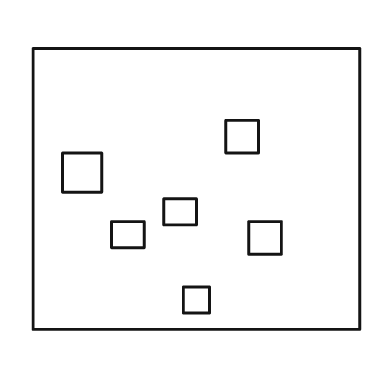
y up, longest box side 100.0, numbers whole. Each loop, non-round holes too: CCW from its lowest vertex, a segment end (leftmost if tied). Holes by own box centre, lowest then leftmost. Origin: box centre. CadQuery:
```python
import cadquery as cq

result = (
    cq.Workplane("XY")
    .moveTo(-50.0, -43.0)
    .lineTo(50.0, -43.0)
    .lineTo(50.0, 43.0)
    .lineTo(-50.0, 43.0)
    .close()
    .moveTo(-4.0, -38.0)
    .lineTo(4.0, -38.0)
    .lineTo(4.0, -30.0)
    .lineTo(-4.0, -30.0)
    .close()
    .moveTo(16.0, -20.0)
    .lineTo(26.0, -20.0)
    .lineTo(26.0, -10.0)
    .lineTo(16.0, -10.0)
    .close()
    .moveTo(-26.0, -18.0)
    .lineTo(-16.0, -18.0)
    .lineTo(-16.0, -10.0)
    .lineTo(-26.0, -10.0)
    .close()
    .moveTo(-10.0, -11.0)
    .lineTo(0.0, -11.0)
    .lineTo(0.0, -3.0)
    .lineTo(-10.0, -3.0)
    .close()
    .moveTo(-41.0, -1.0)
    .lineTo(-29.0, -1.0)
    .lineTo(-29.0, 11.0)
    .lineTo(-41.0, 11.0)
    .close()
    .moveTo(9.0, 11.0)
    .lineTo(19.0, 11.0)
    .lineTo(19.0, 21.0)
    .lineTo(9.0, 21.0)
    .close()
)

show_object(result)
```